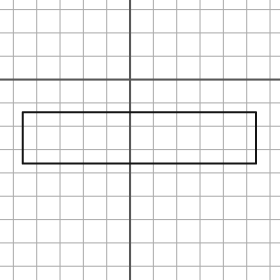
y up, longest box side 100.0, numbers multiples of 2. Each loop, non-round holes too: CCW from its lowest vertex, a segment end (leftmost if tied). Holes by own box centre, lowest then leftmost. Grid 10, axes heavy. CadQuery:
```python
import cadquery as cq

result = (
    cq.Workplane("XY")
    .moveTo(-46.0, -36.0)
    .lineTo(54.0, -36.0)
    .lineTo(54.0, -14.0)
    .lineTo(-46.0, -14.0)
    .close()
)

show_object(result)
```